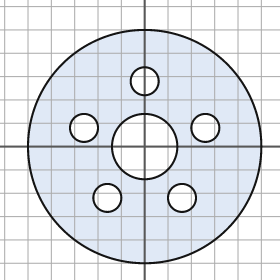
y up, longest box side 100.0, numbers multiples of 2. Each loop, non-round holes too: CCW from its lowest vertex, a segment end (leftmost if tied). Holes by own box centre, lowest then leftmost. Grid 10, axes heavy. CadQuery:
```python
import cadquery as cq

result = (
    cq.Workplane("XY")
    .moveTo(0.0, 0.0)
    .circle(50.0)
    .moveTo(-16.0, -22.0)
    .circle(6.0)
    .moveTo(16.0, -22.0)
    .circle(6.0)
    .moveTo(0.0, 0.0)
    .circle(14.0)
    .moveTo(-26.0, 8.0)
    .circle(6.0)
    .moveTo(26.0, 8.0)
    .circle(6.0)
    .moveTo(0.0, 28.0)
    .circle(6.0)
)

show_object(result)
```